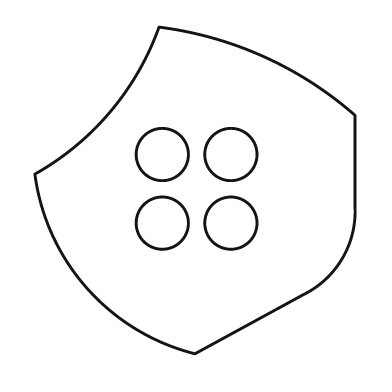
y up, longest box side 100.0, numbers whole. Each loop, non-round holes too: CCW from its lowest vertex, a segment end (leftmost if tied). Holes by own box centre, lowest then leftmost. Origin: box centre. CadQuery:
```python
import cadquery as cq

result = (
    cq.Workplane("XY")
    .moveTo(0.0, -50.0)
    .lineTo(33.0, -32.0)
    .threePointArc((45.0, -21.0), (49.0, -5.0))
    .lineTo(49.0, 23.0)
    .threePointArc((21.0, 41.0), (-11.0, 50.0))
    .threePointArc((-26.0, 24.0), (-49.0, 5.0))
    .threePointArc((-33.0, -30.0), (0.0, -50.0))
    .close()
    .moveTo(-10.0, -10.0)
    .circle(8.0)
    .moveTo(11.0, -10.0)
    .circle(8.0)
    .moveTo(-10.0, 11.0)
    .circle(8.0)
    .moveTo(11.0, 11.0)
    .circle(8.0)
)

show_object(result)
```